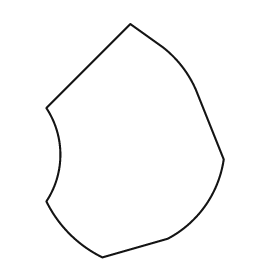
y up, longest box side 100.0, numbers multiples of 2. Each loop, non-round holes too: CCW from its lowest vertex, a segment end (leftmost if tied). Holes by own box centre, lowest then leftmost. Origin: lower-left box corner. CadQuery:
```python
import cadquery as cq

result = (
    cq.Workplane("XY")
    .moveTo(24.0, 0.0)
    .lineTo(52.0, 8.0)
    .threePointArc((68.0, 22.0), (76.0, 42.0))
    .lineTo(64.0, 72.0)
    .threePointArc((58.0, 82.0), (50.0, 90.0))
    .lineTo(36.0, 100.0)
    .lineTo(0.0, 64.0)
    .threePointArc((6.0, 44.0), (0.0, 24.0))
    .threePointArc((10.0, 10.0), (24.0, 0.0))
    .close()
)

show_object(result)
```